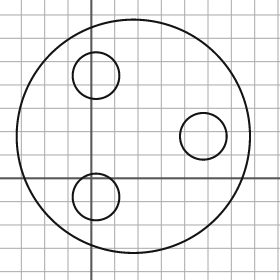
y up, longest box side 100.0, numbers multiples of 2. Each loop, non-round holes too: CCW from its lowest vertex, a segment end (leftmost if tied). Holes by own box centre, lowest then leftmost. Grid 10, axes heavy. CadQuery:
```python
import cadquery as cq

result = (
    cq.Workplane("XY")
    .moveTo(18.0, 18.0)
    .circle(50.0)
    .moveTo(2.0, -8.0)
    .circle(10.0)
    .moveTo(48.0, 18.0)
    .circle(10.0)
    .moveTo(2.0, 44.0)
    .circle(10.0)
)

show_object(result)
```